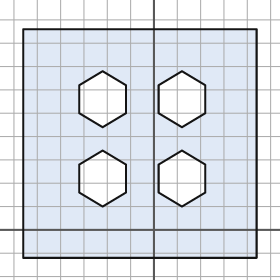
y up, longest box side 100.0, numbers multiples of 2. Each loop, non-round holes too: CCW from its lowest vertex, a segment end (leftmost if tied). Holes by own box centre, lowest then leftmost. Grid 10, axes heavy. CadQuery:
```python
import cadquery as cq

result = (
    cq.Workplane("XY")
    .moveTo(-56.0, -12.0)
    .lineTo(44.0, -12.0)
    .lineTo(44.0, 86.0)
    .lineTo(-56.0, 86.0)
    .close()
    .moveTo(-22.0, 10.0)
    .lineTo(-12.0, 16.0)
    .lineTo(-12.0, 28.0)
    .lineTo(-22.0, 34.0)
    .lineTo(-32.0, 28.0)
    .lineTo(-32.0, 16.0)
    .close()
    .moveTo(12.0, 10.0)
    .lineTo(22.0, 16.0)
    .lineTo(22.0, 28.0)
    .lineTo(12.0, 34.0)
    .lineTo(2.0, 28.0)
    .lineTo(2.0, 16.0)
    .close()
    .moveTo(-22.0, 44.0)
    .lineTo(-12.0, 50.0)
    .lineTo(-12.0, 62.0)
    .lineTo(-22.0, 68.0)
    .lineTo(-32.0, 62.0)
    .lineTo(-32.0, 50.0)
    .close()
    .moveTo(12.0, 44.0)
    .lineTo(22.0, 50.0)
    .lineTo(22.0, 62.0)
    .lineTo(12.0, 68.0)
    .lineTo(2.0, 62.0)
    .lineTo(2.0, 50.0)
    .close()
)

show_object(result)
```